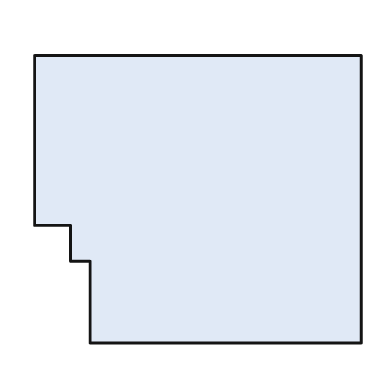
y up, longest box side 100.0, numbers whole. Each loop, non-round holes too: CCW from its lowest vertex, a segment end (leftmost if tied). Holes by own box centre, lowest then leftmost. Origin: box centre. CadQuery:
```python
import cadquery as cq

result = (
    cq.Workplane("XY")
    .moveTo(-33.0, -44.0)
    .lineTo(50.0, -44.0)
    .lineTo(50.0, 44.0)
    .lineTo(-50.0, 44.0)
    .lineTo(-50.0, -8.0)
    .lineTo(-39.0, -8.0)
    .lineTo(-39.0, -19.0)
    .lineTo(-33.0, -19.0)
    .close()
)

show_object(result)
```